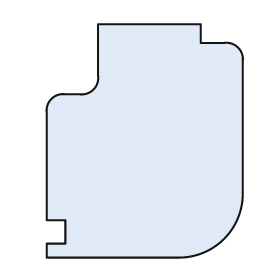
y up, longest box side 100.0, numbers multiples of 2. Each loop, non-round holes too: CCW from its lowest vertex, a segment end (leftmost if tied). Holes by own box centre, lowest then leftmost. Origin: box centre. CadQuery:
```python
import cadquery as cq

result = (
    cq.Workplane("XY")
    .moveTo(-42.0, -50.0)
    .lineTo(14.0, -50.0)
    .threePointArc((34.0, -42.0), (42.0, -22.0))
    .lineTo(42.0, 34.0)
    .threePointArc((40.0, 40.0), (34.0, 42.0))
    .lineTo(24.0, 42.0)
    .lineTo(24.0, 50.0)
    .lineTo(-20.0, 50.0)
    .lineTo(-20.0, 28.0)
    .threePointArc((-22.0, 22.0), (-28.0, 20.0))
    .lineTo(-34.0, 20.0)
    .threePointArc((-40.0, 18.0), (-42.0, 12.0))
    .lineTo(-42.0, -34.0)
    .lineTo(-34.0, -34.0)
    .lineTo(-34.0, -44.0)
    .lineTo(-42.0, -44.0)
    .close()
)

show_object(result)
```